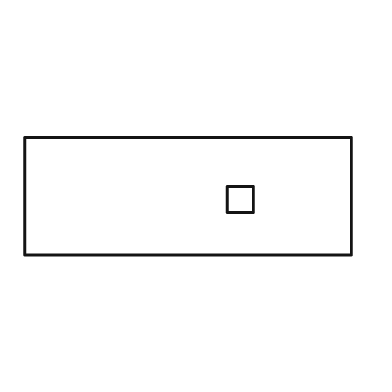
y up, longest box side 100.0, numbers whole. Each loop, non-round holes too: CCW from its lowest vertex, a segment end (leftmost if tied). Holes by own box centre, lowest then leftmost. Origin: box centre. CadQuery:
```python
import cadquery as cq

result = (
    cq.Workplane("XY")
    .moveTo(-50.0, -18.0)
    .lineTo(50.0, -18.0)
    .lineTo(50.0, 18.0)
    .lineTo(-50.0, 18.0)
    .close()
    .moveTo(12.0, -5.0)
    .lineTo(20.0, -5.0)
    .lineTo(20.0, 3.0)
    .lineTo(12.0, 3.0)
    .close()
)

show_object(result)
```